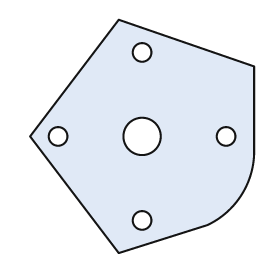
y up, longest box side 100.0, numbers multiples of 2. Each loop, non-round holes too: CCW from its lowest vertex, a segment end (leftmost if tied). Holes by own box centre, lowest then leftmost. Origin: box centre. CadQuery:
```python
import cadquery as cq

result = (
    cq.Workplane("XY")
    .moveTo(-10.0, -50.0)
    .lineTo(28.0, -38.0)
    .threePointArc((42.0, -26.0), (48.0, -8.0))
    .lineTo(48.0, 30.0)
    .lineTo(-10.0, 50.0)
    .lineTo(-48.0, 0.0)
    .close()
    .moveTo(0.0, -36.0)
    .circle(4.0)
    .moveTo(-36.0, 0.0)
    .circle(4.0)
    .moveTo(0.0, 0.0)
    .circle(8.0)
    .moveTo(36.0, 0.0)
    .circle(4.0)
    .moveTo(0.0, 36.0)
    .circle(4.0)
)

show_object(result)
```